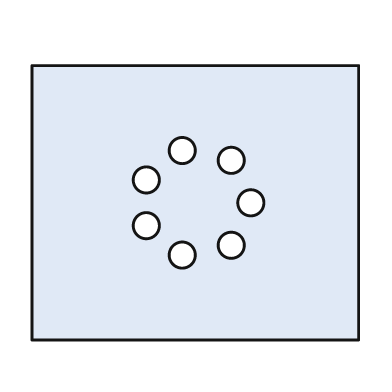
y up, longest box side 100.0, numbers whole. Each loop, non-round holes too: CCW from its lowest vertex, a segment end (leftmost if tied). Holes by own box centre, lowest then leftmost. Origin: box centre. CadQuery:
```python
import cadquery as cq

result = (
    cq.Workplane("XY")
    .moveTo(-50.0, -42.0)
    .lineTo(50.0, -42.0)
    .lineTo(50.0, 42.0)
    .lineTo(-50.0, 42.0)
    .close()
    .moveTo(-4.0, -16.0)
    .circle(4.0)
    .moveTo(11.0, -13.0)
    .circle(4.0)
    .moveTo(-15.0, -7.0)
    .circle(4.0)
    .moveTo(17.0, 0.0)
    .circle(4.0)
    .moveTo(-15.0, 7.0)
    .circle(4.0)
    .moveTo(11.0, 13.0)
    .circle(4.0)
    .moveTo(-4.0, 16.0)
    .circle(4.0)
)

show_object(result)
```